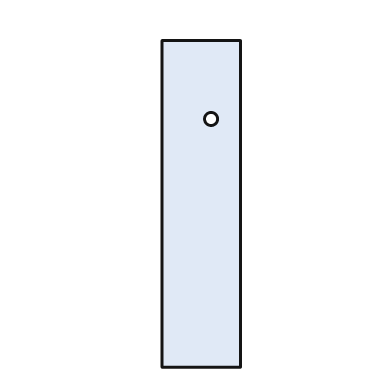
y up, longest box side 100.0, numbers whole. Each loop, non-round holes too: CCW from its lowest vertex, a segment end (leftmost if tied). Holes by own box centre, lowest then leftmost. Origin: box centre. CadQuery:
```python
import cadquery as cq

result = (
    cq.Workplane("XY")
    .moveTo(-12.0, -50.0)
    .lineTo(12.0, -50.0)
    .lineTo(12.0, 50.0)
    .lineTo(-12.0, 50.0)
    .close()
    .moveTo(3.0, 26.0)
    .circle(2.0)
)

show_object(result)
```